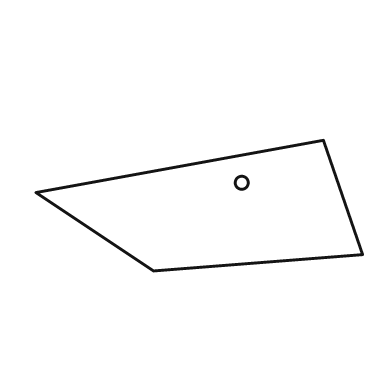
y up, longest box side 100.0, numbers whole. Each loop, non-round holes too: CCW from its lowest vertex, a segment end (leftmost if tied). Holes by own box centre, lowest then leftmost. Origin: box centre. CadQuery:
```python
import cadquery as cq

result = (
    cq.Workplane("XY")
    .moveTo(-14.0, -20.0)
    .lineTo(50.0, -15.0)
    .lineTo(38.0, 20.0)
    .lineTo(-50.0, 4.0)
    .close()
    .moveTo(13.0, 7.0)
    .circle(2.0)
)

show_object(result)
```